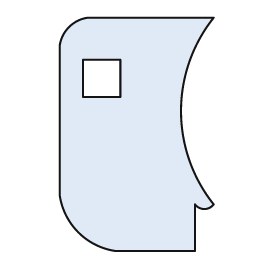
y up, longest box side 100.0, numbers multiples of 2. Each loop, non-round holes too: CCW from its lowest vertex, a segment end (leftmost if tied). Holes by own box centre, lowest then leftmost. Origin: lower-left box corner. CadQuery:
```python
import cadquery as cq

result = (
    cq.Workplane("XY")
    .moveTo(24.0, 0.0)
    .lineTo(58.0, 0.0)
    .lineTo(58.0, 20.0)
    .threePointArc((62.0, 18.0), (66.0, 20.0))
    .threePointArc((52.0, 60.0), (66.0, 100.0))
    .lineTo(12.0, 100.0)
    .threePointArc((4.0, 96.0), (0.0, 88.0))
    .lineTo(0.0, 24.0)
    .threePointArc((8.0, 8.0), (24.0, 0.0))
    .close()
    .moveTo(10.0, 66.0)
    .lineTo(26.0, 66.0)
    .lineTo(26.0, 82.0)
    .lineTo(10.0, 82.0)
    .close()
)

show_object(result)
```